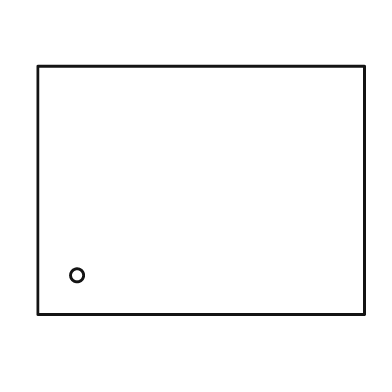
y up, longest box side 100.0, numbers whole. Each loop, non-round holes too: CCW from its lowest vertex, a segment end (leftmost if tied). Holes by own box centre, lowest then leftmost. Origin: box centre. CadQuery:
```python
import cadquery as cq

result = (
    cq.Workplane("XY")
    .moveTo(-50.0, -38.0)
    .lineTo(50.0, -38.0)
    .lineTo(50.0, 38.0)
    .lineTo(-50.0, 38.0)
    .close()
    .moveTo(-38.0, -26.0)
    .circle(2.0)
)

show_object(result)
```